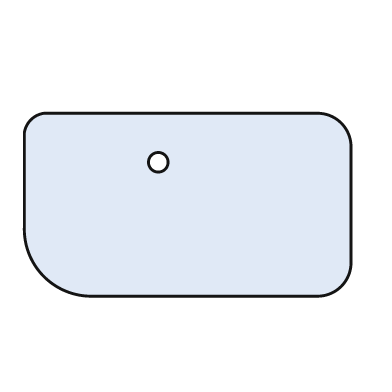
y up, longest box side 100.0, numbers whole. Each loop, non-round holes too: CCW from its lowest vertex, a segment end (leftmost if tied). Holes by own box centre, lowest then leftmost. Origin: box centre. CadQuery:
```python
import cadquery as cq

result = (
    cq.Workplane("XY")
    .moveTo(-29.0, -28.0)
    .lineTo(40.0, -28.0)
    .threePointArc((47.0, -25.0), (50.0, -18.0))
    .lineTo(50.0, 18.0)
    .threePointArc((47.0, 25.0), (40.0, 28.0))
    .lineTo(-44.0, 28.0)
    .threePointArc((-48.0, 26.0), (-50.0, 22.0))
    .lineTo(-50.0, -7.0)
    .threePointArc((-44.0, -22.0), (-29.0, -28.0))
    .close()
    .moveTo(-9.0, 13.0)
    .circle(3.0)
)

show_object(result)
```